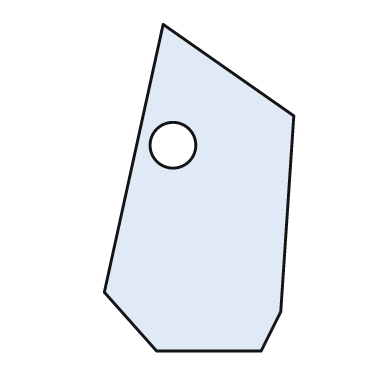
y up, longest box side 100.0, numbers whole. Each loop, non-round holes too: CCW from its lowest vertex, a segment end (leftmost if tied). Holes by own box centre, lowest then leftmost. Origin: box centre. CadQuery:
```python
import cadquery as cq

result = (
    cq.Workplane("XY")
    .moveTo(-13.0, -50.0)
    .lineTo(19.0, -50.0)
    .lineTo(25.0, -38.0)
    .lineTo(29.0, 22.0)
    .lineTo(-11.0, 50.0)
    .lineTo(-29.0, -32.0)
    .close()
    .moveTo(-8.0, 13.0)
    .circle(7.0)
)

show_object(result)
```